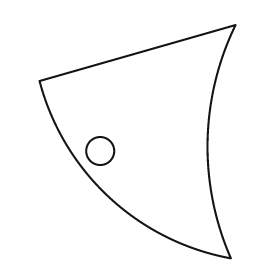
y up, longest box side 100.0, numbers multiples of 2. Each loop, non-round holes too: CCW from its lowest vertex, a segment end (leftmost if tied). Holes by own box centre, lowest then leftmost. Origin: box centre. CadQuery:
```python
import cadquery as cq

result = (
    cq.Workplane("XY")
    .moveTo(40.0, -50.0)
    .threePointArc((30.0, 0.0), (42.0, 50.0))
    .lineTo(-42.0, 26.0)
    .threePointArc((-12.0, -24.0), (40.0, -50.0))
    .close()
    .moveTo(-16.0, -4.0)
    .circle(6.0)
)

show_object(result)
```